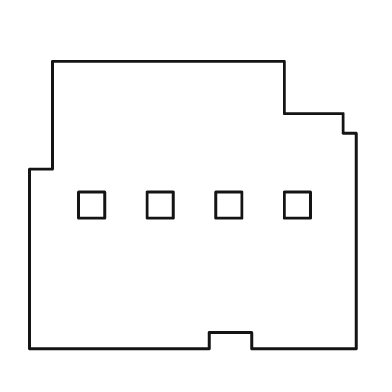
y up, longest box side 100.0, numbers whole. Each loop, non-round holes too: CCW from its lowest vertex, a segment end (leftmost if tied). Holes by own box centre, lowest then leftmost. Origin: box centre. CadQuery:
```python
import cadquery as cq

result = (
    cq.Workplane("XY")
    .moveTo(-50.0, -44.0)
    .lineTo(5.0, -44.0)
    .lineTo(5.0, -39.0)
    .lineTo(18.0, -39.0)
    .lineTo(18.0, -44.0)
    .lineTo(50.0, -44.0)
    .lineTo(50.0, 22.0)
    .lineTo(46.0, 22.0)
    .lineTo(46.0, 28.0)
    .lineTo(28.0, 28.0)
    .lineTo(28.0, 44.0)
    .lineTo(-43.0, 44.0)
    .lineTo(-43.0, 11.0)
    .lineTo(-50.0, 11.0)
    .close()
    .moveTo(-35.0, -4.0)
    .lineTo(-27.0, -4.0)
    .lineTo(-27.0, 4.0)
    .lineTo(-35.0, 4.0)
    .close()
    .moveTo(-14.0, -4.0)
    .lineTo(-6.0, -4.0)
    .lineTo(-6.0, 4.0)
    .lineTo(-14.0, 4.0)
    .close()
    .moveTo(7.0, -4.0)
    .lineTo(15.0, -4.0)
    .lineTo(15.0, 4.0)
    .lineTo(7.0, 4.0)
    .close()
    .moveTo(28.0, -4.0)
    .lineTo(36.0, -4.0)
    .lineTo(36.0, 4.0)
    .lineTo(28.0, 4.0)
    .close()
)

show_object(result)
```